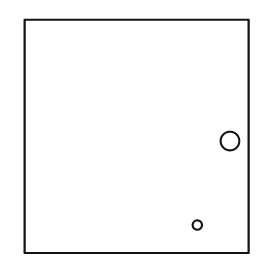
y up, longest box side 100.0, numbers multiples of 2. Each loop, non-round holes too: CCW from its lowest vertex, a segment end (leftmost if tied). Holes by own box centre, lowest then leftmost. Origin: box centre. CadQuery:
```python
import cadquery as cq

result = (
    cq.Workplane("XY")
    .moveTo(-48.0, -50.0)
    .lineTo(48.0, -50.0)
    .lineTo(48.0, 50.0)
    .lineTo(-48.0, 50.0)
    .close()
    .moveTo(26.0, -38.0)
    .circle(2.0)
    .moveTo(40.0, -2.0)
    .circle(4.0)
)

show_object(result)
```